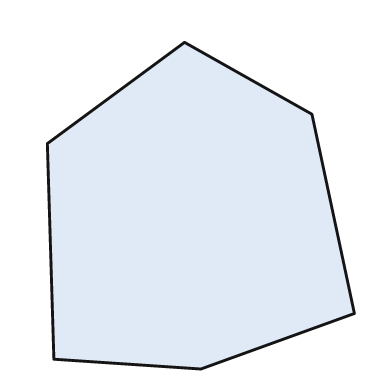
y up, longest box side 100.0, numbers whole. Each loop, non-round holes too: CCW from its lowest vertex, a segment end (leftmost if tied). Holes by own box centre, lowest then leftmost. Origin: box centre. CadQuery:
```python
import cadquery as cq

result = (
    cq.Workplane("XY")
    .moveTo(0.0, -50.0)
    .lineTo(47.0, -33.0)
    .lineTo(34.0, 28.0)
    .lineTo(-5.0, 50.0)
    .lineTo(-47.0, 19.0)
    .lineTo(-45.0, -47.0)
    .close()
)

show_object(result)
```